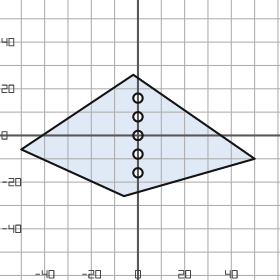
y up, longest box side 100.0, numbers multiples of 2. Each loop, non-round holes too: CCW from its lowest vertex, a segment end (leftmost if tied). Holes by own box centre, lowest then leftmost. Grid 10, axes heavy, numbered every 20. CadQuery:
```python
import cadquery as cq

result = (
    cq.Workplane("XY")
    .moveTo(-6.0, -26.0)
    .lineTo(50.0, -10.0)
    .lineTo(-2.0, 26.0)
    .lineTo(-50.0, -6.0)
    .close()
    .moveTo(0.0, -16.0)
    .circle(2.0)
    .moveTo(0.0, -8.0)
    .circle(2.0)
    .moveTo(0.0, 0.0)
    .circle(2.0)
    .moveTo(0.0, 8.0)
    .circle(2.0)
    .moveTo(0.0, 16.0)
    .circle(2.0)
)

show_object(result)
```